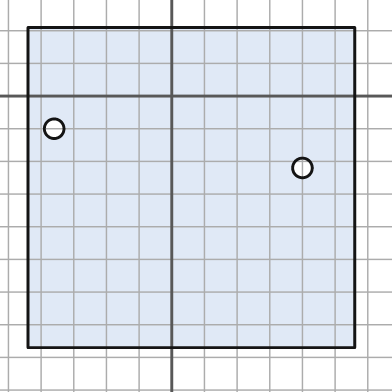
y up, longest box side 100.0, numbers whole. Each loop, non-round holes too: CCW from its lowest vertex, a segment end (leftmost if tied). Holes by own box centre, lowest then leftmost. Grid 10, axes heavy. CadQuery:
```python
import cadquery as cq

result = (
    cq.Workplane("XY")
    .moveTo(-44.0, -77.0)
    .lineTo(56.0, -77.0)
    .lineTo(56.0, 21.0)
    .lineTo(-44.0, 21.0)
    .close()
    .moveTo(40.0, -22.0)
    .circle(3.0)
    .moveTo(-36.0, -10.0)
    .circle(3.0)
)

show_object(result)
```